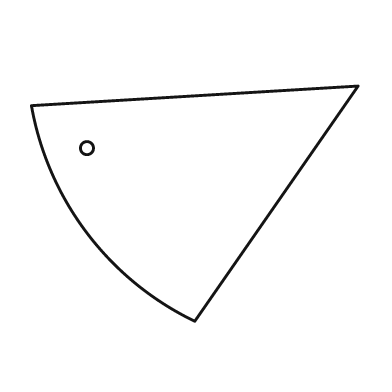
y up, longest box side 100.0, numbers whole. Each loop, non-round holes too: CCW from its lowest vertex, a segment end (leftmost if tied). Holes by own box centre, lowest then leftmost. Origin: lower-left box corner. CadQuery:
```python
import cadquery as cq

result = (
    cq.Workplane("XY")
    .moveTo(50.0, 0.0)
    .lineTo(100.0, 72.0)
    .lineTo(0.0, 66.0)
    .threePointArc((17.0, 27.0), (50.0, 0.0))
    .close()
    .moveTo(17.0, 53.0)
    .circle(2.0)
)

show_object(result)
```